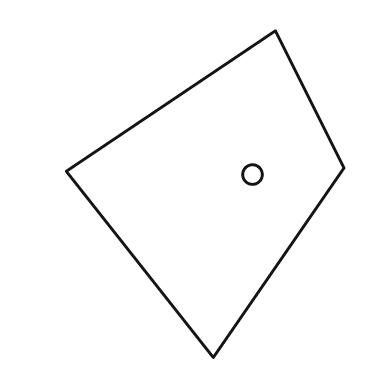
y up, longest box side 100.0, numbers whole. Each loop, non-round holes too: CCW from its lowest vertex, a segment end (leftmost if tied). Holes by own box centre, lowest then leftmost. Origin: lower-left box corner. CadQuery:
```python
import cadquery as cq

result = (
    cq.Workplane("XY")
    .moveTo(45.0, 0.0)
    .lineTo(85.0, 58.0)
    .lineTo(64.0, 100.0)
    .lineTo(0.0, 57.0)
    .close()
    .moveTo(57.0, 56.0)
    .circle(3.0)
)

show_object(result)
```